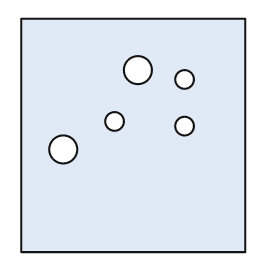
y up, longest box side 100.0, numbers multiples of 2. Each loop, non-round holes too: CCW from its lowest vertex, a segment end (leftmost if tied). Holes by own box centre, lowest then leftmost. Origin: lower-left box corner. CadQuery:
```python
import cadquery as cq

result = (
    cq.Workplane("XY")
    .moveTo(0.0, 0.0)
    .lineTo(96.0, 0.0)
    .lineTo(96.0, 100.0)
    .lineTo(0.0, 100.0)
    .close()
    .moveTo(18.0, 44.0)
    .circle(6.0)
    .moveTo(70.0, 54.0)
    .circle(4.0)
    .moveTo(40.0, 56.0)
    .circle(4.0)
    .moveTo(70.0, 74.0)
    .circle(4.0)
    .moveTo(50.0, 78.0)
    .circle(6.0)
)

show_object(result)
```